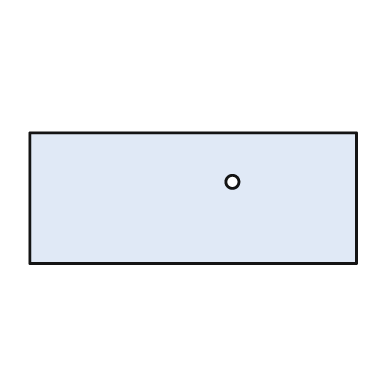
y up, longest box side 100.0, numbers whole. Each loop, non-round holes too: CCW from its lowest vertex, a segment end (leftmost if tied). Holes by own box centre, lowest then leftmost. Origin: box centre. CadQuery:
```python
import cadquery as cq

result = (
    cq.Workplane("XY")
    .moveTo(-50.0, -20.0)
    .lineTo(50.0, -20.0)
    .lineTo(50.0, 20.0)
    .lineTo(-50.0, 20.0)
    .close()
    .moveTo(12.0, 5.0)
    .circle(2.0)
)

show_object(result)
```